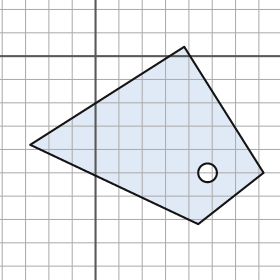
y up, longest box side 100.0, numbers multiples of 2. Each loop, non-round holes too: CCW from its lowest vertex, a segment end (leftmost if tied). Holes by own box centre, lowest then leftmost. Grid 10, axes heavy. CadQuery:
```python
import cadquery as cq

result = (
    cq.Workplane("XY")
    .moveTo(44.0, -72.0)
    .lineTo(72.0, -50.0)
    .lineTo(38.0, 4.0)
    .lineTo(-28.0, -38.0)
    .close()
    .moveTo(48.0, -50.0)
    .circle(4.0)
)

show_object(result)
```